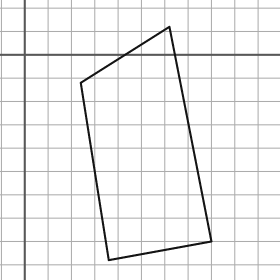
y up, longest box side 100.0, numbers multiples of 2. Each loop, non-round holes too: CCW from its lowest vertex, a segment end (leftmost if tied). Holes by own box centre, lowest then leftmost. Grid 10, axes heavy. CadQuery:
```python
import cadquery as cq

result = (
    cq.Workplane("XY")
    .moveTo(36.0, -88.0)
    .lineTo(80.0, -80.0)
    .lineTo(62.0, 12.0)
    .lineTo(24.0, -12.0)
    .close()
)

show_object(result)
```